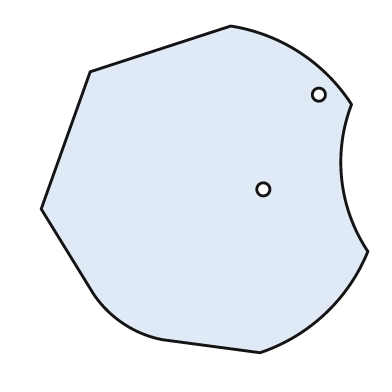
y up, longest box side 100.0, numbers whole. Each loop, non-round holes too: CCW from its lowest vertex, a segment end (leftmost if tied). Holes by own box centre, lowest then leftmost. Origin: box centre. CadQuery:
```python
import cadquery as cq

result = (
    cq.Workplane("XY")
    .moveTo(17.0, -50.0)
    .threePointArc((37.0, -38.0), (50.0, -19.0))
    .threePointArc((42.0, 3.0), (45.0, 26.0))
    .threePointArc((29.0, 42.0), (8.0, 50.0))
    .lineTo(-35.0, 36.0)
    .lineTo(-50.0, -6.0)
    .lineTo(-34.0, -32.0)
    .threePointArc((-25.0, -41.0), (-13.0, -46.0))
    .close()
    .moveTo(18.0, 0.0)
    .circle(2.0)
    .moveTo(35.0, 29.0)
    .circle(2.0)
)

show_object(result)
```